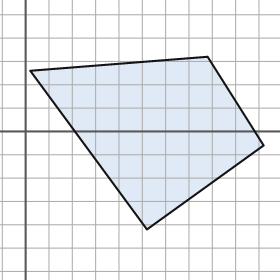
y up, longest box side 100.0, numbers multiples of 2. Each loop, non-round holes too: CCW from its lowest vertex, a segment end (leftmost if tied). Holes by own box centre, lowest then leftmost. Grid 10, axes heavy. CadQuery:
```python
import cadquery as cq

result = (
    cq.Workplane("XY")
    .moveTo(52.0, -42.0)
    .lineTo(102.0, -6.0)
    .lineTo(78.0, 32.0)
    .lineTo(2.0, 26.0)
    .close()
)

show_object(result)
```